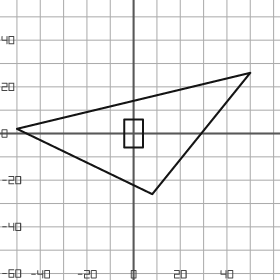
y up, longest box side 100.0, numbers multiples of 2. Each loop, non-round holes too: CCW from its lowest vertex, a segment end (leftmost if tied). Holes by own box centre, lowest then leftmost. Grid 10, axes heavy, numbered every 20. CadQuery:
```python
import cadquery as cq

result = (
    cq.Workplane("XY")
    .moveTo(8.0, -26.0)
    .lineTo(50.0, 26.0)
    .lineTo(-50.0, 2.0)
    .close()
    .moveTo(-4.0, -6.0)
    .lineTo(4.0, -6.0)
    .lineTo(4.0, 6.0)
    .lineTo(-4.0, 6.0)
    .close()
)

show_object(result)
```